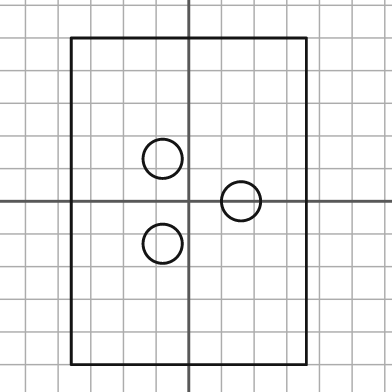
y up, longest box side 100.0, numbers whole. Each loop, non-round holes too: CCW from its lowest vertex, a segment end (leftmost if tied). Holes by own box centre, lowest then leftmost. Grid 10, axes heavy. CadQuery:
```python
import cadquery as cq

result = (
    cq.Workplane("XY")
    .moveTo(-36.0, -50.0)
    .lineTo(36.0, -50.0)
    .lineTo(36.0, 50.0)
    .lineTo(-36.0, 50.0)
    .close()
    .moveTo(-8.0, -13.0)
    .circle(6.0)
    .moveTo(16.0, 0.0)
    .circle(6.0)
    .moveTo(-8.0, 13.0)
    .circle(6.0)
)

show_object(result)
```